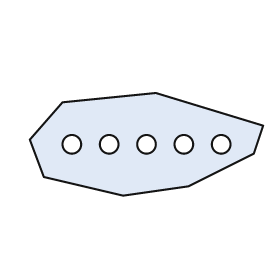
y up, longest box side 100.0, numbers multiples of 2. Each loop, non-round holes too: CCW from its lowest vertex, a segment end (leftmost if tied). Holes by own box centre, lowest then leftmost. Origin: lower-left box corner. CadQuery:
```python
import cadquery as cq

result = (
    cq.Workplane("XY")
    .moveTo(40.0, 0.0)
    .lineTo(68.0, 4.0)
    .lineTo(96.0, 18.0)
    .lineTo(100.0, 30.0)
    .lineTo(54.0, 44.0)
    .lineTo(14.0, 40.0)
    .lineTo(0.0, 24.0)
    .lineTo(6.0, 8.0)
    .close()
    .moveTo(18.0, 22.0)
    .circle(4.0)
    .moveTo(34.0, 22.0)
    .circle(4.0)
    .moveTo(50.0, 22.0)
    .circle(4.0)
    .moveTo(66.0, 22.0)
    .circle(4.0)
    .moveTo(82.0, 22.0)
    .circle(4.0)
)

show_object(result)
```